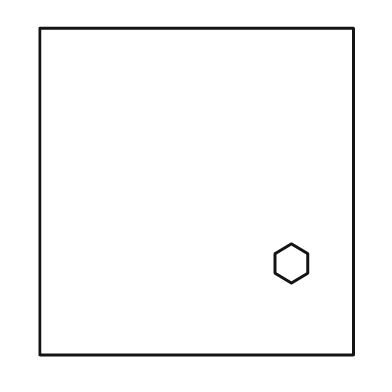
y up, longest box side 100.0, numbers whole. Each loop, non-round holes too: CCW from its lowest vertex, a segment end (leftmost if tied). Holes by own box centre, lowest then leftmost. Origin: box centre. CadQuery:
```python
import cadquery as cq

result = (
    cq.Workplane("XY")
    .moveTo(-48.0, -50.0)
    .lineTo(48.0, -50.0)
    .lineTo(48.0, 50.0)
    .lineTo(-48.0, 50.0)
    .close()
    .moveTo(29.0, -28.0)
    .lineTo(34.0, -25.0)
    .lineTo(34.0, -19.0)
    .lineTo(29.0, -16.0)
    .lineTo(24.0, -19.0)
    .lineTo(24.0, -25.0)
    .close()
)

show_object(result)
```